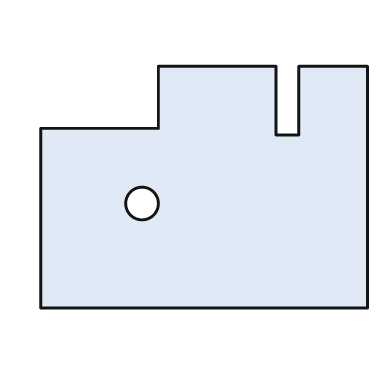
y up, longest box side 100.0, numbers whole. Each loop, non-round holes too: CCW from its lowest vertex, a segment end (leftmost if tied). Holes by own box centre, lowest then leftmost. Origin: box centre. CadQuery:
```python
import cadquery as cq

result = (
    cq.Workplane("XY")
    .moveTo(-50.0, -37.0)
    .lineTo(50.0, -37.0)
    .lineTo(50.0, 37.0)
    .lineTo(29.0, 37.0)
    .lineTo(29.0, 16.0)
    .lineTo(22.0, 16.0)
    .lineTo(22.0, 37.0)
    .lineTo(-14.0, 37.0)
    .lineTo(-14.0, 18.0)
    .lineTo(-50.0, 18.0)
    .close()
    .moveTo(-19.0, -5.0)
    .circle(5.0)
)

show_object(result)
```